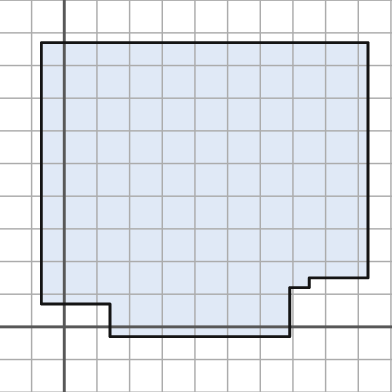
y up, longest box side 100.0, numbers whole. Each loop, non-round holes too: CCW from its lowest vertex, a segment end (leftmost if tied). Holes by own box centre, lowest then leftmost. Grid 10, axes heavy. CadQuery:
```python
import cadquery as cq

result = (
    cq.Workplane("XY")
    .moveTo(14.0, -3.0)
    .lineTo(69.0, -3.0)
    .lineTo(69.0, 12.0)
    .lineTo(75.0, 12.0)
    .lineTo(75.0, 15.0)
    .lineTo(93.0, 15.0)
    .lineTo(93.0, 87.0)
    .lineTo(-7.0, 87.0)
    .lineTo(-7.0, 7.0)
    .lineTo(14.0, 7.0)
    .close()
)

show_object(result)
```